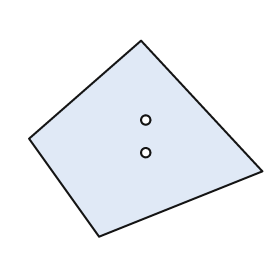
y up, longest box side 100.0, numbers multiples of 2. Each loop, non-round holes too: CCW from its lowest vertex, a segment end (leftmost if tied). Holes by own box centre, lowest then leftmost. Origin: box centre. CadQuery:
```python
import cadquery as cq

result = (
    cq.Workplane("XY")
    .moveTo(-20.0, -42.0)
    .lineTo(50.0, -14.0)
    .lineTo(-2.0, 42.0)
    .lineTo(-50.0, 0.0)
    .close()
    .moveTo(0.0, -6.0)
    .circle(2.0)
    .moveTo(0.0, 8.0)
    .circle(2.0)
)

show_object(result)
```